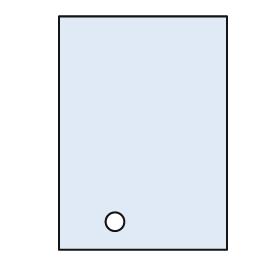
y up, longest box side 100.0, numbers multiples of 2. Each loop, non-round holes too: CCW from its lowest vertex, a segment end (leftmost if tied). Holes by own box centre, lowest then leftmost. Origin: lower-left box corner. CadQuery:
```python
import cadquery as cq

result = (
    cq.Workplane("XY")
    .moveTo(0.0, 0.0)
    .lineTo(72.0, 0.0)
    .lineTo(72.0, 100.0)
    .lineTo(0.0, 100.0)
    .close()
    .moveTo(24.0, 12.0)
    .circle(4.0)
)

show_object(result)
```